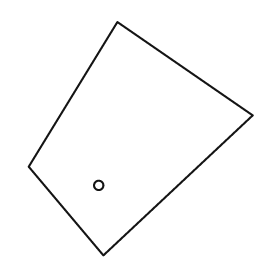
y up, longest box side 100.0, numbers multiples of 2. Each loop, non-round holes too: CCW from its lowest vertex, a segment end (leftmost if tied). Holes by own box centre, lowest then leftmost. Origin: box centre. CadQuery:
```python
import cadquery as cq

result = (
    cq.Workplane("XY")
    .moveTo(-16.0, -50.0)
    .lineTo(48.0, 10.0)
    .lineTo(-10.0, 50.0)
    .lineTo(-48.0, -12.0)
    .close()
    .moveTo(-18.0, -20.0)
    .circle(2.0)
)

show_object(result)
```